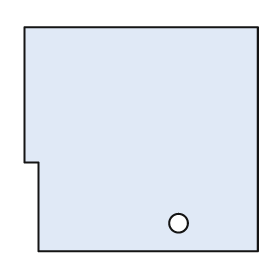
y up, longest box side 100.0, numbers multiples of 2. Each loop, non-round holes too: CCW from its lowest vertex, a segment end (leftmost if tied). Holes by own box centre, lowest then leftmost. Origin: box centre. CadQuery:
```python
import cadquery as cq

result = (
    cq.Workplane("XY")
    .moveTo(-44.0, -48.0)
    .lineTo(50.0, -48.0)
    .lineTo(50.0, 48.0)
    .lineTo(-50.0, 48.0)
    .lineTo(-50.0, -10.0)
    .lineTo(-44.0, -10.0)
    .close()
    .moveTo(16.0, -36.0)
    .circle(4.0)
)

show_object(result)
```